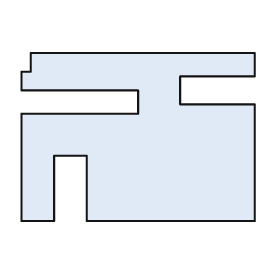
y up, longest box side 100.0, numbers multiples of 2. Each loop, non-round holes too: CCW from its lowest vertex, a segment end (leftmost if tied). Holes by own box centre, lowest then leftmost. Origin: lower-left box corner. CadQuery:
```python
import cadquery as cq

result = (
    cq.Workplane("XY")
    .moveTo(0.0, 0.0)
    .lineTo(14.0, 0.0)
    .lineTo(14.0, 28.0)
    .lineTo(28.0, 28.0)
    .lineTo(28.0, 0.0)
    .lineTo(100.0, 0.0)
    .lineTo(100.0, 50.0)
    .lineTo(68.0, 50.0)
    .lineTo(68.0, 62.0)
    .lineTo(100.0, 62.0)
    .lineTo(100.0, 72.0)
    .lineTo(4.0, 72.0)
    .lineTo(4.0, 64.0)
    .lineTo(0.0, 64.0)
    .lineTo(0.0, 56.0)
    .lineTo(50.0, 56.0)
    .lineTo(50.0, 46.0)
    .lineTo(0.0, 46.0)
    .close()
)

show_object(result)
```